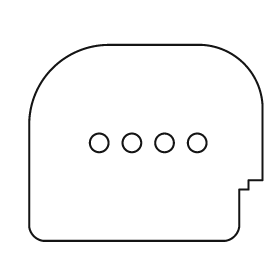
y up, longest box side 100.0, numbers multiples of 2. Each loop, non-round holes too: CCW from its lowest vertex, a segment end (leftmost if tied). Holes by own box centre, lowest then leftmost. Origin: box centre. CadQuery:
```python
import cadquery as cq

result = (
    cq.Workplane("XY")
    .moveTo(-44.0, -42.0)
    .lineTo(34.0, -42.0)
    .threePointArc((38.0, -40.0), (40.0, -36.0))
    .lineTo(40.0, -20.0)
    .lineTo(44.0, -20.0)
    .lineTo(44.0, -16.0)
    .lineTo(50.0, -16.0)
    .lineTo(50.0, 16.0)
    .threePointArc((42.0, 34.0), (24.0, 42.0))
    .lineTo(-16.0, 42.0)
    .threePointArc((-40.0, 32.0), (-50.0, 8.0))
    .lineTo(-50.0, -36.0)
    .threePointArc((-48.0, -40.0), (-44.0, -42.0))
    .close()
    .moveTo(-20.0, 0.0)
    .circle(4.0)
    .moveTo(-6.0, 0.0)
    .circle(4.0)
    .moveTo(8.0, 0.0)
    .circle(4.0)
    .moveTo(22.0, 0.0)
    .circle(4.0)
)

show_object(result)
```